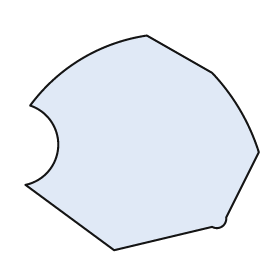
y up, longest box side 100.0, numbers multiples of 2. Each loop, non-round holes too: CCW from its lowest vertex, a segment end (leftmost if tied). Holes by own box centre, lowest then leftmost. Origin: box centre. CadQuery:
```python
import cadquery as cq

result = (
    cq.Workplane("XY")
    .moveTo(-12.0, -46.0)
    .lineTo(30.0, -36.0)
    .threePointArc((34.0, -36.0), (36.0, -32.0))
    .lineTo(50.0, -4.0)
    .threePointArc((42.0, 14.0), (30.0, 30.0))
    .lineTo(2.0, 46.0)
    .threePointArc((-26.0, 36.0), (-48.0, 16.0))
    .threePointArc((-36.0, -2.0), (-50.0, -18.0))
    .close()
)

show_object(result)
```